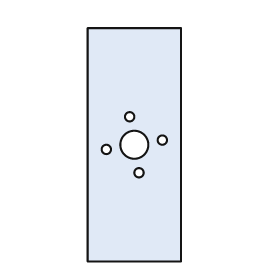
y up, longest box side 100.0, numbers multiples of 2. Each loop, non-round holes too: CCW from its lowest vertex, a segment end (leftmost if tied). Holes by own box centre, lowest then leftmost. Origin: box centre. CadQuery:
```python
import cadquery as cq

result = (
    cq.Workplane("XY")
    .moveTo(-20.0, -50.0)
    .lineTo(20.0, -50.0)
    .lineTo(20.0, 50.0)
    .lineTo(-20.0, 50.0)
    .close()
    .moveTo(2.0, -12.0)
    .circle(2.0)
    .moveTo(-12.0, -2.0)
    .circle(2.0)
    .moveTo(0.0, 0.0)
    .circle(6.0)
    .moveTo(12.0, 2.0)
    .circle(2.0)
    .moveTo(-2.0, 12.0)
    .circle(2.0)
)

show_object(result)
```